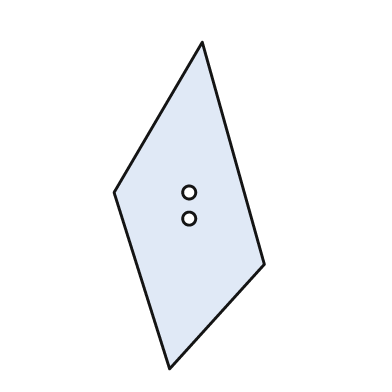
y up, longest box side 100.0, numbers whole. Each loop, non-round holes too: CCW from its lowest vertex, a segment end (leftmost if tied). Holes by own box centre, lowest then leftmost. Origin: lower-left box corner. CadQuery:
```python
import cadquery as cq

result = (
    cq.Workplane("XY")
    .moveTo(17.0, 0.0)
    .lineTo(46.0, 32.0)
    .lineTo(27.0, 100.0)
    .lineTo(0.0, 54.0)
    .close()
    .moveTo(23.0, 46.0)
    .circle(2.0)
    .moveTo(23.0, 54.0)
    .circle(2.0)
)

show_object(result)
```